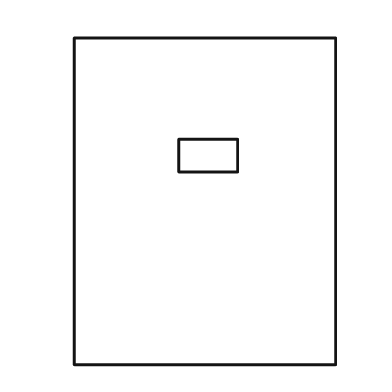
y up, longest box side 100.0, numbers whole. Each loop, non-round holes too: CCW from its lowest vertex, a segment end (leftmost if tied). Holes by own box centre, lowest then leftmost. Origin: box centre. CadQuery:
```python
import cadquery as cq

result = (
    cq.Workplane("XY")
    .moveTo(-40.0, -50.0)
    .lineTo(40.0, -50.0)
    .lineTo(40.0, 50.0)
    .lineTo(-40.0, 50.0)
    .close()
    .moveTo(-8.0, 9.0)
    .lineTo(10.0, 9.0)
    .lineTo(10.0, 19.0)
    .lineTo(-8.0, 19.0)
    .close()
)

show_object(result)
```